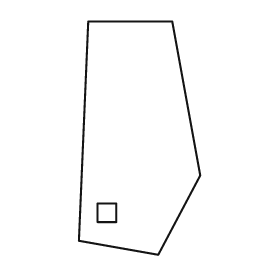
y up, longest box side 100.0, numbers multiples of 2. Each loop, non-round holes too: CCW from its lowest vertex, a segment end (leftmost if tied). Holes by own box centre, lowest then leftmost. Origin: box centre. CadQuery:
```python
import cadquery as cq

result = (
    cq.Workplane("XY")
    .moveTo(8.0, -50.0)
    .lineTo(26.0, -16.0)
    .lineTo(14.0, 50.0)
    .lineTo(-22.0, 50.0)
    .lineTo(-26.0, -44.0)
    .close()
    .moveTo(-18.0, -36.0)
    .lineTo(-10.0, -36.0)
    .lineTo(-10.0, -28.0)
    .lineTo(-18.0, -28.0)
    .close()
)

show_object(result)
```